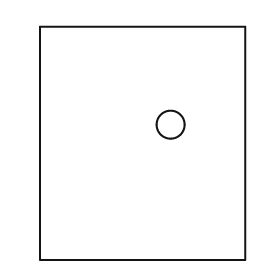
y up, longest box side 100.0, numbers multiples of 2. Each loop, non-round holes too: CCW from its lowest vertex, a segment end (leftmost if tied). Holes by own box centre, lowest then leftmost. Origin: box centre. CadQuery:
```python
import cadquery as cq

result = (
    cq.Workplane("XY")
    .moveTo(-44.0, -50.0)
    .lineTo(44.0, -50.0)
    .lineTo(44.0, 50.0)
    .lineTo(-44.0, 50.0)
    .close()
    .moveTo(12.0, 8.0)
    .circle(6.0)
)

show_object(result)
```